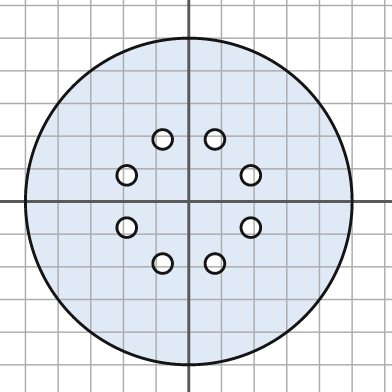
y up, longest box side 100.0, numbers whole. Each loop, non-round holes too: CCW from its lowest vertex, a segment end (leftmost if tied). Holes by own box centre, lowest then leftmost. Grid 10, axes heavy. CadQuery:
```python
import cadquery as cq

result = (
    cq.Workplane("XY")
    .moveTo(0.0, 0.0)
    .circle(50.0)
    .moveTo(-8.0, -19.0)
    .circle(3.0)
    .moveTo(8.0, -19.0)
    .circle(3.0)
    .moveTo(-19.0, -8.0)
    .circle(3.0)
    .moveTo(19.0, -8.0)
    .circle(3.0)
    .moveTo(-19.0, 8.0)
    .circle(3.0)
    .moveTo(19.0, 8.0)
    .circle(3.0)
    .moveTo(-8.0, 19.0)
    .circle(3.0)
    .moveTo(8.0, 19.0)
    .circle(3.0)
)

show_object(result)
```